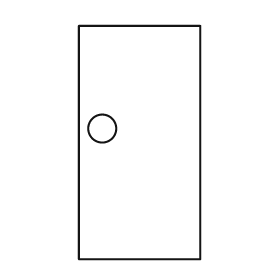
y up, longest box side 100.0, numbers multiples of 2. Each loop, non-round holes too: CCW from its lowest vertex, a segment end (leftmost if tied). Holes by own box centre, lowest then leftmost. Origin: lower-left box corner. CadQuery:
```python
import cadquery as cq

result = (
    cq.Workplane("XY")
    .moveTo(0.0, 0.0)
    .lineTo(52.0, 0.0)
    .lineTo(52.0, 100.0)
    .lineTo(0.0, 100.0)
    .close()
    .moveTo(10.0, 56.0)
    .circle(6.0)
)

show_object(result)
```